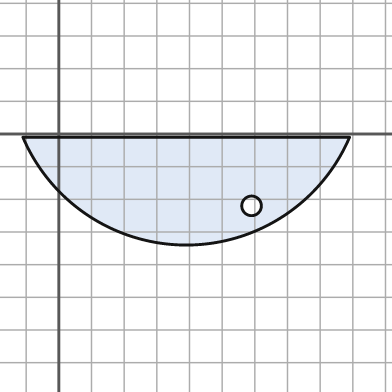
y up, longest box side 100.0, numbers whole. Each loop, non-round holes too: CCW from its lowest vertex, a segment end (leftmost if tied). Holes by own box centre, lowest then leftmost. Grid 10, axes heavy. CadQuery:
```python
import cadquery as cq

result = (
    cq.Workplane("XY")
    .moveTo(-11.0, -1.0)
    .threePointArc((39.0, -34.0), (89.0, -1.0))
    .close()
    .moveTo(59.0, -22.0)
    .circle(3.0)
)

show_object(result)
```